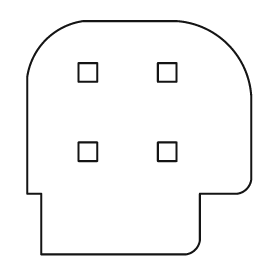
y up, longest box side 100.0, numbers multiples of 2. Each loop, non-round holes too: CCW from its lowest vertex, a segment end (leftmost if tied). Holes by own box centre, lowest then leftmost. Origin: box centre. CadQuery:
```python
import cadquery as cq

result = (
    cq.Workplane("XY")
    .moveTo(-42.0, -50.0)
    .lineTo(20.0, -50.0)
    .threePointArc((24.0, -48.0), (26.0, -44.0))
    .lineTo(26.0, -24.0)
    .lineTo(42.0, -24.0)
    .threePointArc((46.0, -22.0), (48.0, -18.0))
    .lineTo(48.0, 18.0)
    .threePointArc((38.0, 40.0), (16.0, 50.0))
    .lineTo(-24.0, 50.0)
    .threePointArc((-40.0, 42.0), (-48.0, 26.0))
    .lineTo(-48.0, -24.0)
    .lineTo(-42.0, -24.0)
    .close()
    .moveTo(-26.0, -10.0)
    .lineTo(-18.0, -10.0)
    .lineTo(-18.0, -2.0)
    .lineTo(-26.0, -2.0)
    .close()
    .moveTo(8.0, -10.0)
    .lineTo(16.0, -10.0)
    .lineTo(16.0, -2.0)
    .lineTo(8.0, -2.0)
    .close()
    .moveTo(-26.0, 24.0)
    .lineTo(-18.0, 24.0)
    .lineTo(-18.0, 32.0)
    .lineTo(-26.0, 32.0)
    .close()
    .moveTo(8.0, 24.0)
    .lineTo(16.0, 24.0)
    .lineTo(16.0, 32.0)
    .lineTo(8.0, 32.0)
    .close()
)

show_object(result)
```